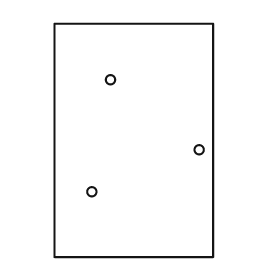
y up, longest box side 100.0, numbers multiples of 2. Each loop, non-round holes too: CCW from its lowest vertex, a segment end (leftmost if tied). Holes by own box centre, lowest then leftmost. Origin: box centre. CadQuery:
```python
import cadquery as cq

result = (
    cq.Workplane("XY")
    .moveTo(-34.0, -50.0)
    .lineTo(34.0, -50.0)
    .lineTo(34.0, 50.0)
    .lineTo(-34.0, 50.0)
    .close()
    .moveTo(-18.0, -22.0)
    .circle(2.0)
    .moveTo(28.0, -4.0)
    .circle(2.0)
    .moveTo(-10.0, 26.0)
    .circle(2.0)
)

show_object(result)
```